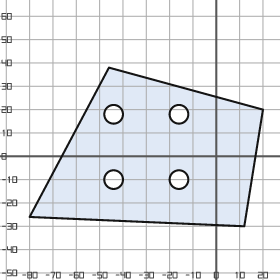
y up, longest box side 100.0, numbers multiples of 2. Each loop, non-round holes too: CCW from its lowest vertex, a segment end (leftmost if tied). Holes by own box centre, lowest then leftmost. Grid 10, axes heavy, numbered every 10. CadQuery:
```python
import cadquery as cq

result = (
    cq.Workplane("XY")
    .moveTo(12.0, -30.0)
    .lineTo(20.0, 20.0)
    .lineTo(-46.0, 38.0)
    .lineTo(-80.0, -26.0)
    .close()
    .moveTo(-44.0, -10.0)
    .circle(4.0)
    .moveTo(-16.0, -10.0)
    .circle(4.0)
    .moveTo(-44.0, 18.0)
    .circle(4.0)
    .moveTo(-16.0, 18.0)
    .circle(4.0)
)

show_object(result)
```